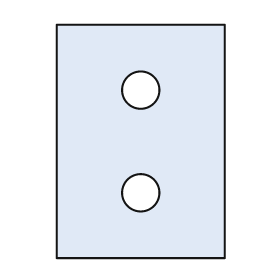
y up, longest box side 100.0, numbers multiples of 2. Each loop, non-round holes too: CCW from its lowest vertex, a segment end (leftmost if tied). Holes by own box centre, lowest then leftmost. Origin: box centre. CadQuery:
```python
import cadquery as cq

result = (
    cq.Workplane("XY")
    .moveTo(-36.0, -50.0)
    .lineTo(36.0, -50.0)
    .lineTo(36.0, 50.0)
    .lineTo(-36.0, 50.0)
    .close()
    .moveTo(0.0, -22.0)
    .circle(8.0)
    .moveTo(0.0, 22.0)
    .circle(8.0)
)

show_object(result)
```